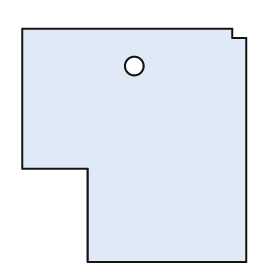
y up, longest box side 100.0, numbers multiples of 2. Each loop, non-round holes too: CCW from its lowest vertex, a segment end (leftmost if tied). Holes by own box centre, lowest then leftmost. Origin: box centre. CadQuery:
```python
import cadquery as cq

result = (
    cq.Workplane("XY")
    .moveTo(-20.0, -50.0)
    .lineTo(48.0, -50.0)
    .lineTo(48.0, 46.0)
    .lineTo(42.0, 46.0)
    .lineTo(42.0, 50.0)
    .lineTo(-48.0, 50.0)
    .lineTo(-48.0, -10.0)
    .lineTo(-20.0, -10.0)
    .close()
    .moveTo(0.0, 34.0)
    .circle(4.0)
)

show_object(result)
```